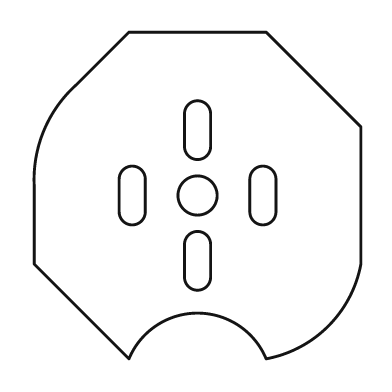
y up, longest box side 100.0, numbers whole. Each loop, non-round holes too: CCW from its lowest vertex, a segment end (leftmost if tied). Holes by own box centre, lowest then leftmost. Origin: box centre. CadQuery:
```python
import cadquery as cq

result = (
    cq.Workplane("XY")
    .moveTo(-21.0, -50.0)
    .threePointArc((0.0, -36.0), (21.0, -50.0))
    .threePointArc((40.0, -40.0), (50.0, -21.0))
    .lineTo(50.0, 21.0)
    .lineTo(21.0, 50.0)
    .lineTo(-21.0, 50.0)
    .lineTo(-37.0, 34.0)
    .threePointArc((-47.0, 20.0), (-50.0, 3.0))
    .lineTo(-50.0, -21.0)
    .close()
    .moveTo(-4.0, -25.0)
    .threePointArc((0.0, -29.0), (4.0, -25.0))
    .lineTo(4.0, -15.0)
    .threePointArc((0.0, -11.0), (-4.0, -15.0))
    .close()
    .moveTo(-24.0, -5.0)
    .threePointArc((-20.0, -9.0), (-16.0, -5.0))
    .lineTo(-16.0, 5.0)
    .threePointArc((-20.0, 9.0), (-24.0, 5.0))
    .close()
    .moveTo(0.0, 0.0)
    .circle(6.0)
    .moveTo(16.0, -5.0)
    .threePointArc((20.0, -9.0), (24.0, -5.0))
    .lineTo(24.0, 5.0)
    .threePointArc((20.0, 9.0), (16.0, 5.0))
    .close()
    .moveTo(-4.0, 15.0)
    .threePointArc((0.0, 11.0), (4.0, 15.0))
    .lineTo(4.0, 25.0)
    .threePointArc((0.0, 29.0), (-4.0, 25.0))
    .close()
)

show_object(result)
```